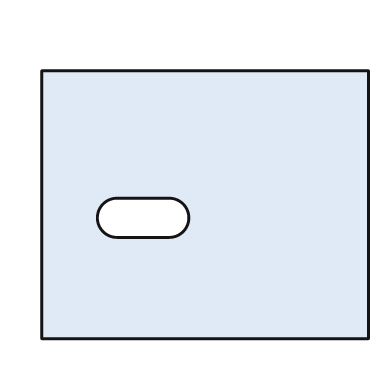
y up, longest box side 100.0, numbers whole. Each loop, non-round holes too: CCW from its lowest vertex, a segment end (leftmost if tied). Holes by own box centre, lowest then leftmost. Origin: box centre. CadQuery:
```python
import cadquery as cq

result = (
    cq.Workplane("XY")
    .moveTo(-50.0, -41.0)
    .lineTo(50.0, -41.0)
    .lineTo(50.0, 41.0)
    .lineTo(-50.0, 41.0)
    .close()
    .moveTo(-27.0, -10.0)
    .lineTo(-11.0, -10.0)
    .threePointArc((-5.0, -4.0), (-11.0, 2.0))
    .lineTo(-27.0, 2.0)
    .threePointArc((-33.0, -4.0), (-27.0, -10.0))
    .close()
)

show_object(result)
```